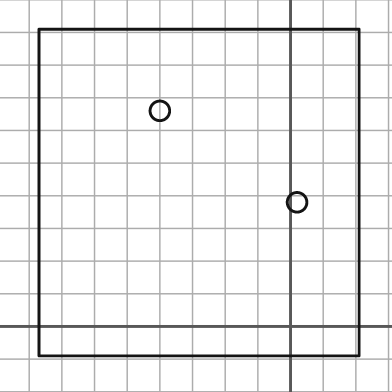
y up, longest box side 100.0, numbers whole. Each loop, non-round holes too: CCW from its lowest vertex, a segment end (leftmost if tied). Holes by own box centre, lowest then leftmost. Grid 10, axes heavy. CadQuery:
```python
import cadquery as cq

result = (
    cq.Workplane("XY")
    .moveTo(-77.0, -9.0)
    .lineTo(21.0, -9.0)
    .lineTo(21.0, 91.0)
    .lineTo(-77.0, 91.0)
    .close()
    .moveTo(2.0, 38.0)
    .circle(3.0)
    .moveTo(-40.0, 66.0)
    .circle(3.0)
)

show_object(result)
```